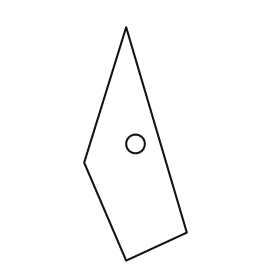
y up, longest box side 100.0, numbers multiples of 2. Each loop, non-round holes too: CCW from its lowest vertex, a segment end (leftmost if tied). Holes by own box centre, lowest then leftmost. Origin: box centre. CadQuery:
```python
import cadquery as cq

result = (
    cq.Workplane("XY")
    .moveTo(-4.0, -50.0)
    .lineTo(22.0, -38.0)
    .lineTo(-4.0, 50.0)
    .lineTo(-22.0, -8.0)
    .close()
    .moveTo(0.0, 0.0)
    .circle(4.0)
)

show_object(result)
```